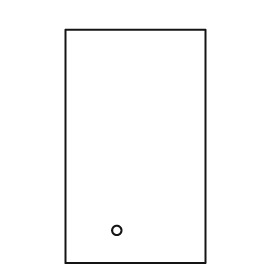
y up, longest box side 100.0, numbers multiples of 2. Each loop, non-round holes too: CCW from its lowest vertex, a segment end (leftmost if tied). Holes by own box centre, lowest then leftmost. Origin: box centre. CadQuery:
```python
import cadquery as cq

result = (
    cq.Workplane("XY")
    .moveTo(-30.0, -50.0)
    .lineTo(30.0, -50.0)
    .lineTo(30.0, 50.0)
    .lineTo(-30.0, 50.0)
    .close()
    .moveTo(-8.0, -36.0)
    .circle(2.0)
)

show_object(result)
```